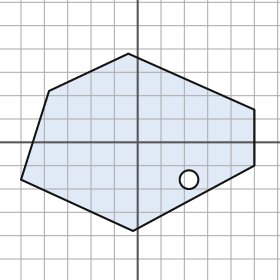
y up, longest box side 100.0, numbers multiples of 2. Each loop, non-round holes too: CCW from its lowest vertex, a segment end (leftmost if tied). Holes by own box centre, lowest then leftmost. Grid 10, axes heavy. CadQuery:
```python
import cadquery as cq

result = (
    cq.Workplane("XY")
    .moveTo(-2.0, -38.0)
    .lineTo(50.0, -10.0)
    .lineTo(50.0, 14.0)
    .lineTo(-4.0, 38.0)
    .lineTo(-38.0, 22.0)
    .lineTo(-50.0, -16.0)
    .close()
    .moveTo(22.0, -16.0)
    .circle(4.0)
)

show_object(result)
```